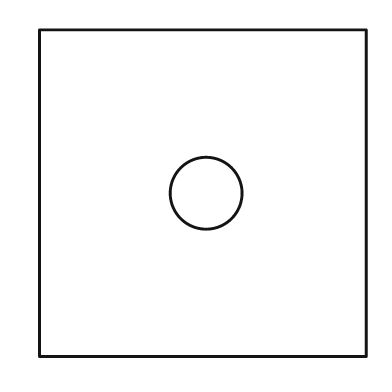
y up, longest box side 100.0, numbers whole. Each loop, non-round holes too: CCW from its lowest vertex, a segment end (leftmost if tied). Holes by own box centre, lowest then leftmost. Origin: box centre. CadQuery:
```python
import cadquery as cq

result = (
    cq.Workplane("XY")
    .moveTo(-50.0, -50.0)
    .lineTo(50.0, -50.0)
    .lineTo(50.0, 50.0)
    .lineTo(-50.0, 50.0)
    .close()
    .moveTo(1.0, 0.0)
    .circle(11.0)
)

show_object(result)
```